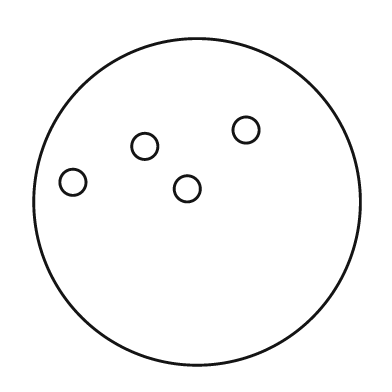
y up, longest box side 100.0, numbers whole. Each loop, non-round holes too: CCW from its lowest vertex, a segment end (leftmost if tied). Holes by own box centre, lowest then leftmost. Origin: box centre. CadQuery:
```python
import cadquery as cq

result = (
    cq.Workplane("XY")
    .moveTo(0.0, 0.0)
    .circle(50.0)
    .moveTo(-3.0, 4.0)
    .circle(4.0)
    .moveTo(-38.0, 6.0)
    .circle(4.0)
    .moveTo(-16.0, 17.0)
    .circle(4.0)
    .moveTo(15.0, 22.0)
    .circle(4.0)
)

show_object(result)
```